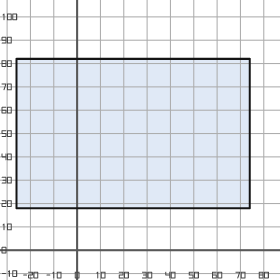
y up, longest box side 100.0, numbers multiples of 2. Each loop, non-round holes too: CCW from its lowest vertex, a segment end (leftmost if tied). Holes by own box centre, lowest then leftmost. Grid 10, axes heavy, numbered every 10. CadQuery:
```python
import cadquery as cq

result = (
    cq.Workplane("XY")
    .moveTo(-26.0, 18.0)
    .lineTo(74.0, 18.0)
    .lineTo(74.0, 82.0)
    .lineTo(-26.0, 82.0)
    .close()
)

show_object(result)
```